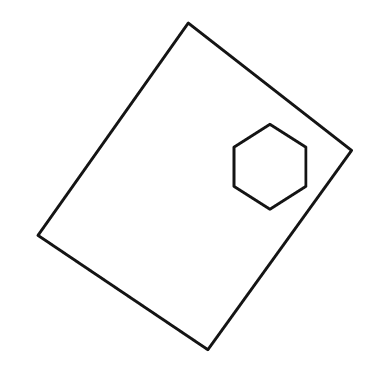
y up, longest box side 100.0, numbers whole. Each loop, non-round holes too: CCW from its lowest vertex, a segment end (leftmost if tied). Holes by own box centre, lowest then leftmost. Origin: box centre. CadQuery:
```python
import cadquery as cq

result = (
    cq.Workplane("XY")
    .moveTo(4.0, -50.0)
    .lineTo(48.0, 11.0)
    .lineTo(-2.0, 50.0)
    .lineTo(-48.0, -15.0)
    .close()
    .moveTo(23.0, -7.0)
    .lineTo(34.0, 0.0)
    .lineTo(34.0, 12.0)
    .lineTo(23.0, 19.0)
    .lineTo(12.0, 12.0)
    .lineTo(12.0, 0.0)
    .close()
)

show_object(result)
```